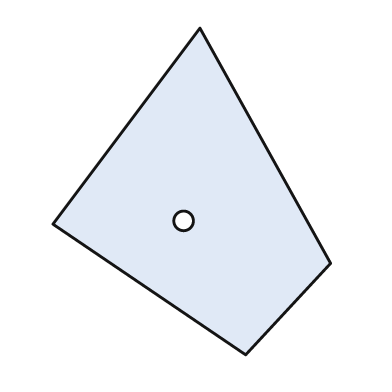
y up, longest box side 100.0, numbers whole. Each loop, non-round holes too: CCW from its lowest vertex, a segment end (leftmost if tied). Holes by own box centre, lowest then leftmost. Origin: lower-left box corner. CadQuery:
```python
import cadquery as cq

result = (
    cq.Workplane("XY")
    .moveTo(59.0, 0.0)
    .lineTo(85.0, 28.0)
    .lineTo(45.0, 100.0)
    .lineTo(0.0, 40.0)
    .close()
    .moveTo(40.0, 41.0)
    .circle(3.0)
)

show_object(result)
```